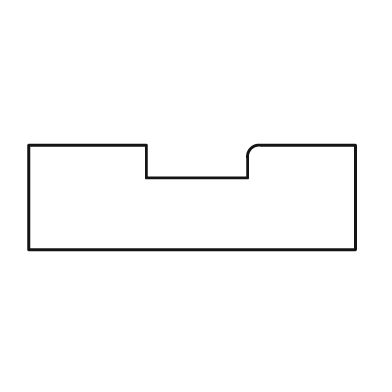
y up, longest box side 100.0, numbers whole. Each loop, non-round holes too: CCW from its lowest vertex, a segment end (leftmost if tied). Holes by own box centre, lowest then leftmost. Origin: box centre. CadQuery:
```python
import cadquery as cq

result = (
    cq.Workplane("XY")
    .moveTo(-50.0, -16.0)
    .lineTo(50.0, -16.0)
    .lineTo(50.0, 16.0)
    .lineTo(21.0, 16.0)
    .threePointArc((18.0, 15.0), (17.0, 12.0))
    .lineTo(17.0, 6.0)
    .lineTo(-14.0, 6.0)
    .lineTo(-14.0, 16.0)
    .lineTo(-50.0, 16.0)
    .close()
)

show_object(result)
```